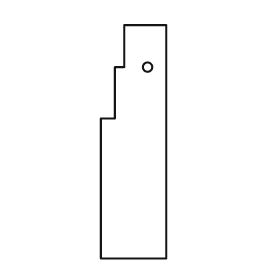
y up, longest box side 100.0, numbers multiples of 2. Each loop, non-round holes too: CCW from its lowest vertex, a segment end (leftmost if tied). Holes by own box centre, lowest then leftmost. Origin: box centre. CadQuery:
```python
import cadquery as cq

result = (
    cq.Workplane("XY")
    .moveTo(-14.0, -50.0)
    .lineTo(14.0, -50.0)
    .lineTo(14.0, 50.0)
    .lineTo(-4.0, 50.0)
    .lineTo(-4.0, 32.0)
    .lineTo(-8.0, 32.0)
    .lineTo(-8.0, 10.0)
    .lineTo(-14.0, 10.0)
    .close()
    .moveTo(6.0, 32.0)
    .circle(2.0)
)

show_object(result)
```